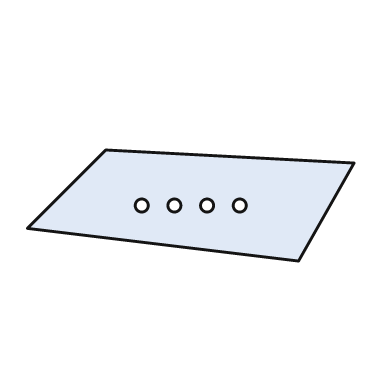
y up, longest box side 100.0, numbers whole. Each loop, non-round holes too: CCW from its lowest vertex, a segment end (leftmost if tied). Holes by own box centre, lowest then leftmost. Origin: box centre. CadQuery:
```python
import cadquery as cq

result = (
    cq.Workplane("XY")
    .moveTo(33.0, -17.0)
    .lineTo(50.0, 13.0)
    .lineTo(-26.0, 17.0)
    .lineTo(-50.0, -7.0)
    .close()
    .moveTo(-15.0, 0.0)
    .circle(2.0)
    .moveTo(-5.0, 0.0)
    .circle(2.0)
    .moveTo(5.0, 0.0)
    .circle(2.0)
    .moveTo(15.0, 0.0)
    .circle(2.0)
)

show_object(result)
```